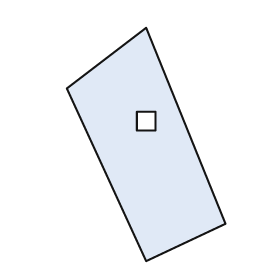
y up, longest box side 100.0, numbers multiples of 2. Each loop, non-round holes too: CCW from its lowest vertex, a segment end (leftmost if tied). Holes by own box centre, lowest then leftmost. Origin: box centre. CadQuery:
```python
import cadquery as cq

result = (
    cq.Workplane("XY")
    .moveTo(0.0, -50.0)
    .lineTo(34.0, -34.0)
    .lineTo(0.0, 50.0)
    .lineTo(-34.0, 24.0)
    .close()
    .moveTo(-4.0, 6.0)
    .lineTo(4.0, 6.0)
    .lineTo(4.0, 14.0)
    .lineTo(-4.0, 14.0)
    .close()
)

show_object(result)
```